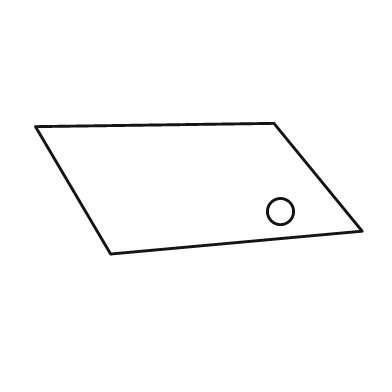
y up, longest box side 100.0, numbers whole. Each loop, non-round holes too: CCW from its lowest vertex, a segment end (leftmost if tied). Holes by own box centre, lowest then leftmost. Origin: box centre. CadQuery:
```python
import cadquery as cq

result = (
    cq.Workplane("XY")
    .moveTo(-27.0, -20.0)
    .lineTo(50.0, -13.0)
    .lineTo(23.0, 20.0)
    .lineTo(-50.0, 19.0)
    .close()
    .moveTo(25.0, -7.0)
    .circle(4.0)
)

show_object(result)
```